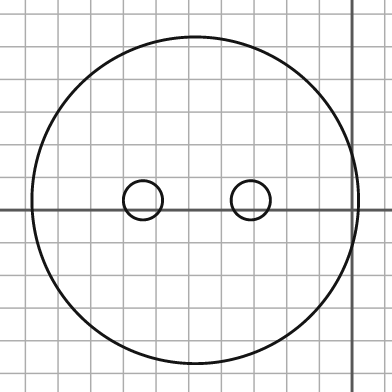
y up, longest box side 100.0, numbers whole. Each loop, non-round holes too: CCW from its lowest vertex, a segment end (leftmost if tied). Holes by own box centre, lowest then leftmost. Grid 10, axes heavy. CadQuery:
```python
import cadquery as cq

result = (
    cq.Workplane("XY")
    .moveTo(-48.0, 3.0)
    .circle(50.0)
    .moveTo(-64.0, 3.0)
    .circle(6.0)
    .moveTo(-31.0, 3.0)
    .circle(6.0)
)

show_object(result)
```